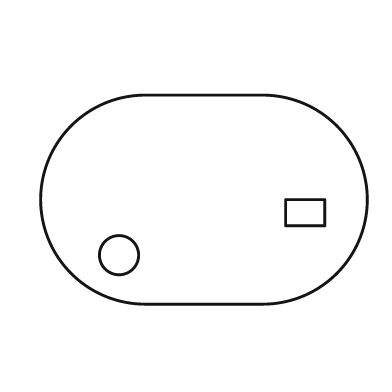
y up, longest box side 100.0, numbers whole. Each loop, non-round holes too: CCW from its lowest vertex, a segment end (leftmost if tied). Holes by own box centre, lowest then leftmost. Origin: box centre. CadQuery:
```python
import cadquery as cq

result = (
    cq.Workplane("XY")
    .moveTo(-18.0, -32.0)
    .lineTo(18.0, -32.0)
    .threePointArc((50.0, 0.0), (18.0, 32.0))
    .lineTo(-18.0, 32.0)
    .threePointArc((-50.0, 0.0), (-18.0, -32.0))
    .close()
    .moveTo(-26.0, -17.0)
    .circle(6.0)
    .moveTo(25.0, -8.0)
    .lineTo(37.0, -8.0)
    .lineTo(37.0, 0.0)
    .lineTo(25.0, 0.0)
    .close()
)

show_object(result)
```